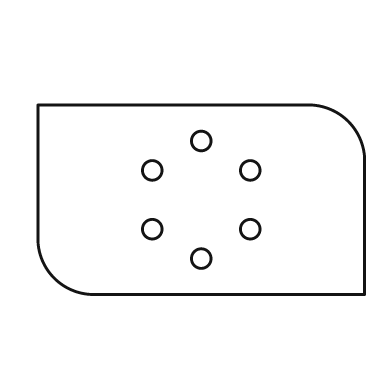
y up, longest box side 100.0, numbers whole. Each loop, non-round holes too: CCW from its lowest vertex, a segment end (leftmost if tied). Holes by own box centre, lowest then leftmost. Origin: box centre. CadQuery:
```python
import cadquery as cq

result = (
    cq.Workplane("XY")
    .moveTo(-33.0, -29.0)
    .lineTo(50.0, -29.0)
    .lineTo(50.0, 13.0)
    .threePointArc((45.0, 24.0), (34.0, 29.0))
    .lineTo(-50.0, 29.0)
    .lineTo(-50.0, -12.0)
    .threePointArc((-45.0, -24.0), (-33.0, -29.0))
    .close()
    .moveTo(0.0, -18.0)
    .circle(3.0)
    .moveTo(-15.0, -9.0)
    .circle(3.0)
    .moveTo(15.0, -9.0)
    .circle(3.0)
    .moveTo(-15.0, 9.0)
    .circle(3.0)
    .moveTo(15.0, 9.0)
    .circle(3.0)
    .moveTo(0.0, 18.0)
    .circle(3.0)
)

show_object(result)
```